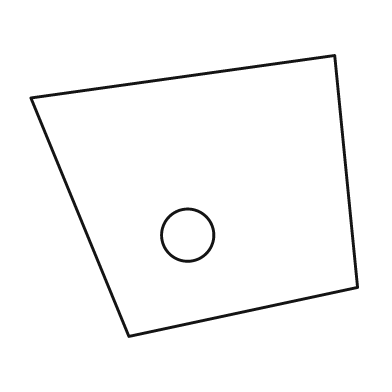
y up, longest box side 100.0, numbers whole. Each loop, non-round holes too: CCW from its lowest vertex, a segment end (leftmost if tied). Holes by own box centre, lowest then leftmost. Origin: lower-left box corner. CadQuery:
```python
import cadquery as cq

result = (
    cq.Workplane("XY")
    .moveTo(30.0, 0.0)
    .lineTo(100.0, 15.0)
    .lineTo(93.0, 86.0)
    .lineTo(0.0, 73.0)
    .close()
    .moveTo(48.0, 31.0)
    .circle(8.0)
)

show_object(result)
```